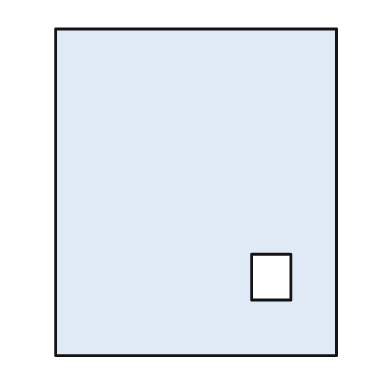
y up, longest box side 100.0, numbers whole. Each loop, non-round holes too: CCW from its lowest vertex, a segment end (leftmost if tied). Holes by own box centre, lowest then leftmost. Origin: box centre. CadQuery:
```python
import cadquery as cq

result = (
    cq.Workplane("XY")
    .moveTo(-43.0, -50.0)
    .lineTo(43.0, -50.0)
    .lineTo(43.0, 50.0)
    .lineTo(-43.0, 50.0)
    .close()
    .moveTo(17.0, -33.0)
    .lineTo(29.0, -33.0)
    .lineTo(29.0, -19.0)
    .lineTo(17.0, -19.0)
    .close()
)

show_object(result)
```